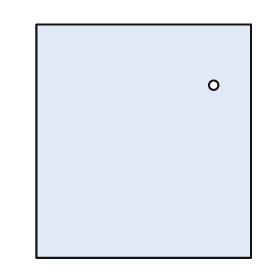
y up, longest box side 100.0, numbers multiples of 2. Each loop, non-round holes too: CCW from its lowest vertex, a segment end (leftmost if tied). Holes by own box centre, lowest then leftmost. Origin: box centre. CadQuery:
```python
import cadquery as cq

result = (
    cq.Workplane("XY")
    .moveTo(-46.0, -50.0)
    .lineTo(46.0, -50.0)
    .lineTo(46.0, 50.0)
    .lineTo(-46.0, 50.0)
    .close()
    .moveTo(30.0, 24.0)
    .circle(2.0)
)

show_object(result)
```